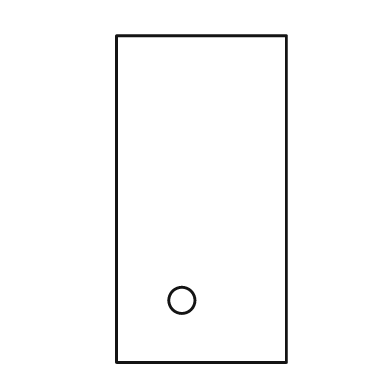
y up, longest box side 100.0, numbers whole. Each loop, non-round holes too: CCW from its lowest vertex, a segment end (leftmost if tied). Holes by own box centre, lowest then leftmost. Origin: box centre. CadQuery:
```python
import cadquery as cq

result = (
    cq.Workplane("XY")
    .moveTo(-26.0, -50.0)
    .lineTo(26.0, -50.0)
    .lineTo(26.0, 50.0)
    .lineTo(-26.0, 50.0)
    .close()
    .moveTo(-6.0, -31.0)
    .circle(4.0)
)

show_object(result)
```